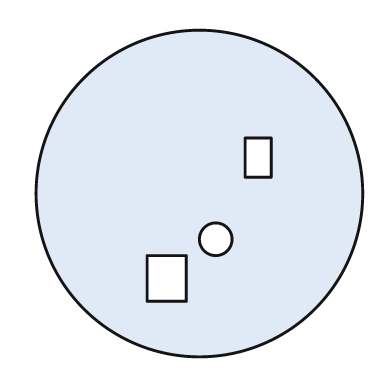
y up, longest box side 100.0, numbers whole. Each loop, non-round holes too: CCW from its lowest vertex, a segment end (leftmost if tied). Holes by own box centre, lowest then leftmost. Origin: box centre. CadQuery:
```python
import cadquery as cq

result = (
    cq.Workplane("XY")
    .moveTo(0.0, 0.0)
    .circle(50.0)
    .moveTo(-16.0, -33.0)
    .lineTo(-4.0, -33.0)
    .lineTo(-4.0, -19.0)
    .lineTo(-16.0, -19.0)
    .close()
    .moveTo(5.0, -14.0)
    .circle(5.0)
    .moveTo(14.0, 5.0)
    .lineTo(22.0, 5.0)
    .lineTo(22.0, 17.0)
    .lineTo(14.0, 17.0)
    .close()
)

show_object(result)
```